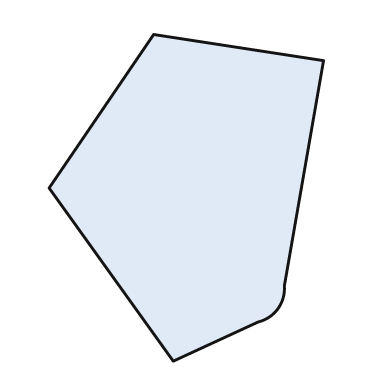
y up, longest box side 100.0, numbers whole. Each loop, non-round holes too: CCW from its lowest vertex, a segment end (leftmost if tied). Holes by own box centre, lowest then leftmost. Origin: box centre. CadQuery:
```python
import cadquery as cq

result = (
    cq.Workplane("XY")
    .moveTo(-4.0, -50.0)
    .lineTo(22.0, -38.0)
    .threePointArc((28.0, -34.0), (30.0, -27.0))
    .lineTo(42.0, 42.0)
    .lineTo(-10.0, 50.0)
    .lineTo(-42.0, 3.0)
    .close()
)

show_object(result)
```